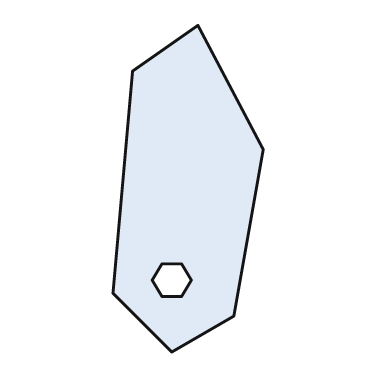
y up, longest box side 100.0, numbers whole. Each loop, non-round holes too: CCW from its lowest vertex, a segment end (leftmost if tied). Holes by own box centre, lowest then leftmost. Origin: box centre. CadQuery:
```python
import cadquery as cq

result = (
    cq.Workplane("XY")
    .moveTo(-5.0, -50.0)
    .lineTo(14.0, -39.0)
    .lineTo(23.0, 12.0)
    .lineTo(3.0, 50.0)
    .lineTo(-17.0, 36.0)
    .lineTo(-23.0, -32.0)
    .close()
    .moveTo(-8.0, -33.0)
    .lineTo(-2.0, -33.0)
    .lineTo(1.0, -28.0)
    .lineTo(-2.0, -23.0)
    .lineTo(-8.0, -23.0)
    .lineTo(-11.0, -28.0)
    .close()
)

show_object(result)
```